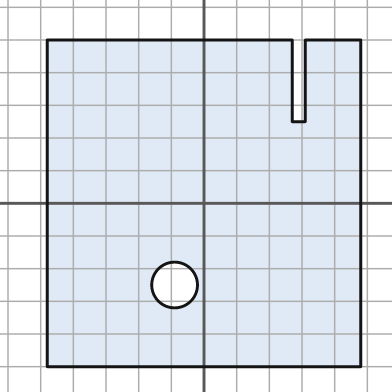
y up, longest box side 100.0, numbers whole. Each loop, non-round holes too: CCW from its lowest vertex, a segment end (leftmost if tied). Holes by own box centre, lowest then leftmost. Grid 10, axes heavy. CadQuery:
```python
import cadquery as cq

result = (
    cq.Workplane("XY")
    .moveTo(-48.0, -50.0)
    .lineTo(48.0, -50.0)
    .lineTo(48.0, 50.0)
    .lineTo(31.0, 50.0)
    .lineTo(31.0, 25.0)
    .lineTo(27.0, 25.0)
    .lineTo(27.0, 50.0)
    .lineTo(-48.0, 50.0)
    .close()
    .moveTo(-9.0, -25.0)
    .circle(7.0)
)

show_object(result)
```